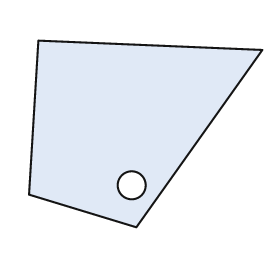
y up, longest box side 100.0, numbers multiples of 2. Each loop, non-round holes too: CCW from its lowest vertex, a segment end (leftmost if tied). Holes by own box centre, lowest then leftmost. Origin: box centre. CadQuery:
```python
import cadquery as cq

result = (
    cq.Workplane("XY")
    .moveTo(-4.0, -40.0)
    .lineTo(50.0, 36.0)
    .lineTo(-46.0, 40.0)
    .lineTo(-50.0, -26.0)
    .close()
    .moveTo(-6.0, -22.0)
    .circle(6.0)
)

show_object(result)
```